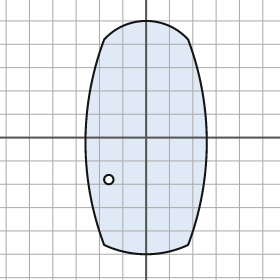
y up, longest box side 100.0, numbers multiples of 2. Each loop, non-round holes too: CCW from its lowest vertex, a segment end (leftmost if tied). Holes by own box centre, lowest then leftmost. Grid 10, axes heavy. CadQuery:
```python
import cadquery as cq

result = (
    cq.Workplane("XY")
    .moveTo(-18.0, -46.0)
    .threePointArc((0.0, -50.0), (18.0, -46.0))
    .threePointArc((26.0, -2.0), (18.0, 42.0))
    .threePointArc((0.0, 50.0), (-18.0, 42.0))
    .threePointArc((-26.0, -2.0), (-18.0, -46.0))
    .close()
    .moveTo(-16.0, -18.0)
    .circle(2.0)
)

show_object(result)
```